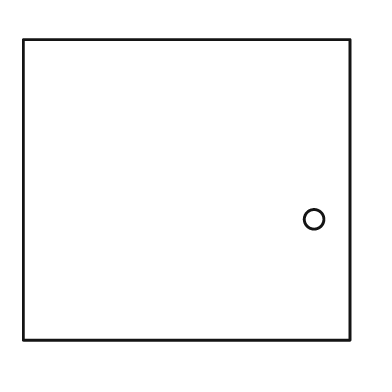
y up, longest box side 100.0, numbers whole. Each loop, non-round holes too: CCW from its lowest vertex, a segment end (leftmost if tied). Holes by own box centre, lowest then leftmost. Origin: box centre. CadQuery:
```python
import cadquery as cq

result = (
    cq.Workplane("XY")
    .moveTo(-50.0, -46.0)
    .lineTo(50.0, -46.0)
    .lineTo(50.0, 46.0)
    .lineTo(-50.0, 46.0)
    .close()
    .moveTo(39.0, -9.0)
    .circle(3.0)
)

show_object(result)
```